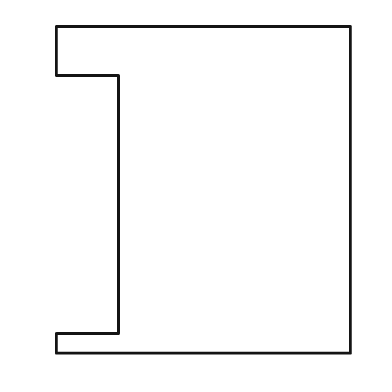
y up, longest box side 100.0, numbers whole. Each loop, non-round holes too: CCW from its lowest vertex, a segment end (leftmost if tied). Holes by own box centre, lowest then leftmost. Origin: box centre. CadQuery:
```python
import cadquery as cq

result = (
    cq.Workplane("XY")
    .moveTo(-45.0, -50.0)
    .lineTo(45.0, -50.0)
    .lineTo(45.0, 50.0)
    .lineTo(-45.0, 50.0)
    .lineTo(-45.0, 35.0)
    .lineTo(-26.0, 35.0)
    .lineTo(-26.0, -44.0)
    .lineTo(-45.0, -44.0)
    .close()
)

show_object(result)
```